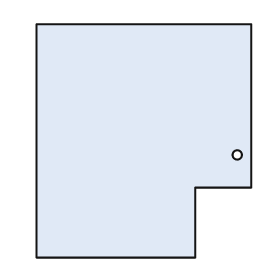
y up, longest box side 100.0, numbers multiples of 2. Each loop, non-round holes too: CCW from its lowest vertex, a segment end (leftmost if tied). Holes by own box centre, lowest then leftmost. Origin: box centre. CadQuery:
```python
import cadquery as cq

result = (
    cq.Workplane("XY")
    .moveTo(-46.0, -50.0)
    .lineTo(22.0, -50.0)
    .lineTo(22.0, -20.0)
    .lineTo(46.0, -20.0)
    .lineTo(46.0, 50.0)
    .lineTo(-46.0, 50.0)
    .close()
    .moveTo(40.0, -6.0)
    .circle(2.0)
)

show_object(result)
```